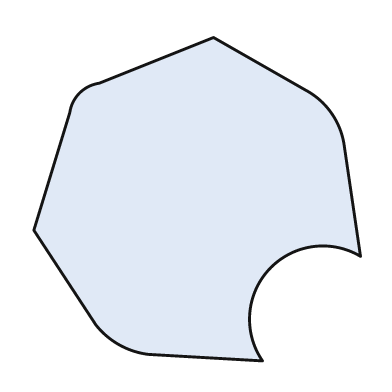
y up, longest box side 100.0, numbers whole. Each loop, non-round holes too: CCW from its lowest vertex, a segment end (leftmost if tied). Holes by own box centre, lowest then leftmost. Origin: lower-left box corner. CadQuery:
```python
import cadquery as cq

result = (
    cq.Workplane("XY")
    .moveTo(70.0, 0.0)
    .threePointArc((72.0, 28.0), (100.0, 32.0))
    .lineTo(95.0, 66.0)
    .threePointArc((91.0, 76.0), (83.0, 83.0))
    .lineTo(55.0, 99.0)
    .lineTo(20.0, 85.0)
    .threePointArc((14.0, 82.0), (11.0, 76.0))
    .lineTo(0.0, 40.0)
    .lineTo(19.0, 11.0)
    .threePointArc((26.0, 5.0), (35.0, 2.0))
    .close()
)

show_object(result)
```